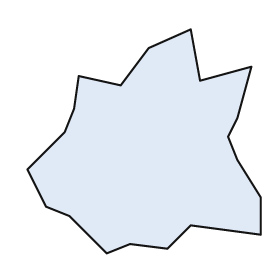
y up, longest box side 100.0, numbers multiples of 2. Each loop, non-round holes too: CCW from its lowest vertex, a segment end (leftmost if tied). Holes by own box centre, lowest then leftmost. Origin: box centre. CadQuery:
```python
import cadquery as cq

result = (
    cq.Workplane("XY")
    .moveTo(-16.0, -48.0)
    .lineTo(-6.0, -44.0)
    .lineTo(10.0, -46.0)
    .lineTo(20.0, -36.0)
    .lineTo(50.0, -40.0)
    .lineTo(50.0, -24.0)
    .lineTo(40.0, -8.0)
    .lineTo(36.0, 2.0)
    .lineTo(40.0, 10.0)
    .lineTo(46.0, 32.0)
    .lineTo(24.0, 26.0)
    .lineTo(20.0, 48.0)
    .lineTo(2.0, 40.0)
    .lineTo(-10.0, 24.0)
    .lineTo(-28.0, 28.0)
    .lineTo(-30.0, 14.0)
    .lineTo(-34.0, 4.0)
    .lineTo(-50.0, -12.0)
    .lineTo(-42.0, -28.0)
    .lineTo(-32.0, -32.0)
    .close()
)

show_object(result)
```